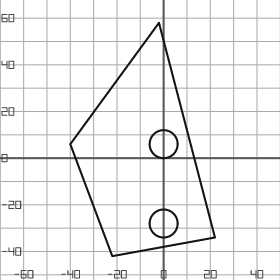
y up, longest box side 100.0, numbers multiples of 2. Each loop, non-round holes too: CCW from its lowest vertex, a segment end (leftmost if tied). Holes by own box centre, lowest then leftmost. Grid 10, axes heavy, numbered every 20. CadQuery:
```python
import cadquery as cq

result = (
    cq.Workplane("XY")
    .moveTo(-22.0, -42.0)
    .lineTo(22.0, -34.0)
    .lineTo(-2.0, 58.0)
    .lineTo(-40.0, 6.0)
    .close()
    .moveTo(0.0, -28.0)
    .circle(6.0)
    .moveTo(0.0, 6.0)
    .circle(6.0)
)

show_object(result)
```